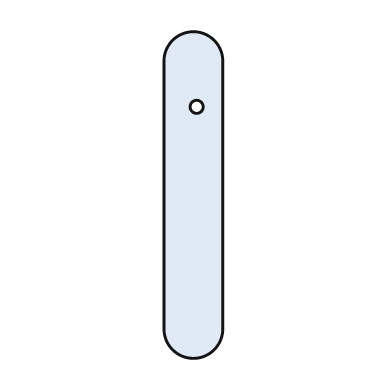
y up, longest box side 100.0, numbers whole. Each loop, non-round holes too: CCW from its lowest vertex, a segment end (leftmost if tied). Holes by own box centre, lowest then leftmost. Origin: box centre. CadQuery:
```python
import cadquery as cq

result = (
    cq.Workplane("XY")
    .moveTo(-9.0, -41.0)
    .threePointArc((0.0, -50.0), (9.0, -41.0))
    .lineTo(9.0, 41.0)
    .threePointArc((0.0, 50.0), (-9.0, 41.0))
    .close()
    .moveTo(1.0, 27.0)
    .circle(2.0)
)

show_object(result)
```